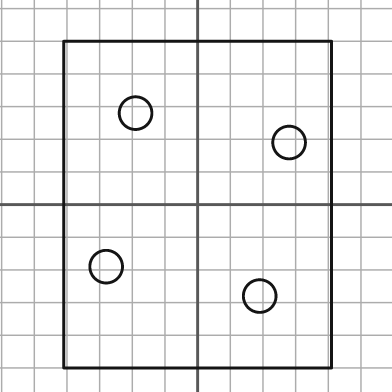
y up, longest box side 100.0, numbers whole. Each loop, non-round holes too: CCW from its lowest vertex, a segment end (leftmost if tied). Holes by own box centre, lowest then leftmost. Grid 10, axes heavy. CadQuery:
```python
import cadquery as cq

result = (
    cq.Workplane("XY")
    .moveTo(-41.0, -50.0)
    .lineTo(41.0, -50.0)
    .lineTo(41.0, 50.0)
    .lineTo(-41.0, 50.0)
    .close()
    .moveTo(19.0, -28.0)
    .circle(5.0)
    .moveTo(-28.0, -19.0)
    .circle(5.0)
    .moveTo(28.0, 19.0)
    .circle(5.0)
    .moveTo(-19.0, 28.0)
    .circle(5.0)
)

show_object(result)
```